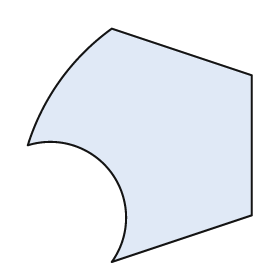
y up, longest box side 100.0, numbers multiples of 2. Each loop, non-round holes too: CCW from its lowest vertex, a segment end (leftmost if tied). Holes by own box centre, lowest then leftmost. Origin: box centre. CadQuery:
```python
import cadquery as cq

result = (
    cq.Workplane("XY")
    .moveTo(-12.0, -50.0)
    .lineTo(48.0, -30.0)
    .lineTo(48.0, 30.0)
    .lineTo(-12.0, 50.0)
    .threePointArc((-34.0, 28.0), (-48.0, 0.0))
    .threePointArc((-12.0, -12.0), (-12.0, -50.0))
    .close()
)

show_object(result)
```